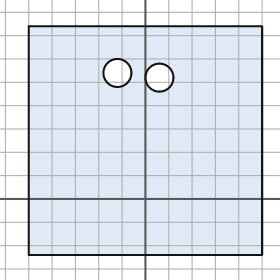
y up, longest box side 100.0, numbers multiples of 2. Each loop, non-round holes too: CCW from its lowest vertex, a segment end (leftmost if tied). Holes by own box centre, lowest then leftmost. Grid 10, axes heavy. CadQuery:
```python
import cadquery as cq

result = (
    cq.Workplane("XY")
    .moveTo(-50.0, -24.0)
    .lineTo(50.0, -24.0)
    .lineTo(50.0, 74.0)
    .lineTo(-50.0, 74.0)
    .close()
    .moveTo(6.0, 52.0)
    .circle(6.0)
    .moveTo(-12.0, 54.0)
    .circle(6.0)
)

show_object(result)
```